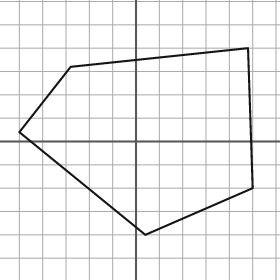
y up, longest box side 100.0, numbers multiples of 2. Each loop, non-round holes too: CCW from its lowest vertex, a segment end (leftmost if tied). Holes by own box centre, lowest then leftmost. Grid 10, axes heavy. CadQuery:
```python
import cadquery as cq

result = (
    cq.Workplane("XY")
    .moveTo(4.0, -40.0)
    .lineTo(50.0, -20.0)
    .lineTo(48.0, 40.0)
    .lineTo(-28.0, 32.0)
    .lineTo(-50.0, 4.0)
    .close()
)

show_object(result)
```